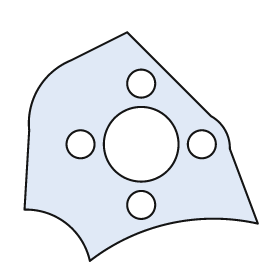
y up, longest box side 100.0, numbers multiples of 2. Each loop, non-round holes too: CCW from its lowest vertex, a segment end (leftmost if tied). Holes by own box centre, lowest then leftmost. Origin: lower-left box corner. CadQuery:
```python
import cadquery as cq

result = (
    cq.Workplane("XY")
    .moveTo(28.0, 0.0)
    .threePointArc((62.0, 16.0), (100.0, 16.0))
    .lineTo(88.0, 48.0)
    .threePointArc((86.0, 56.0), (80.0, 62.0))
    .lineTo(44.0, 98.0)
    .lineTo(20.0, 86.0)
    .threePointArc((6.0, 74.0), (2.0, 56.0))
    .lineTo(0.0, 22.0)
    .threePointArc((18.0, 16.0), (28.0, 0.0))
    .close()
    .moveTo(50.0, 24.0)
    .circle(6.0)
    .moveTo(24.0, 50.0)
    .circle(6.0)
    .moveTo(50.0, 50.0)
    .circle(16.0)
    .moveTo(76.0, 50.0)
    .circle(6.0)
    .moveTo(50.0, 76.0)
    .circle(6.0)
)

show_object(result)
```